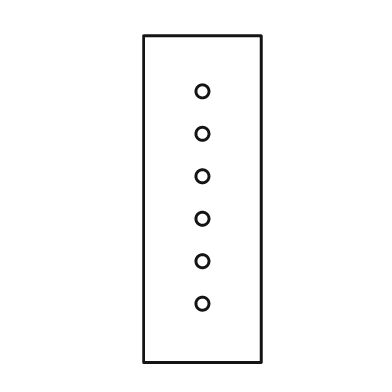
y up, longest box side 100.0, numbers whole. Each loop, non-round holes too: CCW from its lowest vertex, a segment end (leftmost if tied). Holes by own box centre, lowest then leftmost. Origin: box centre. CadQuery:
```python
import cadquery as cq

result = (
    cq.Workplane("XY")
    .moveTo(-18.0, -50.0)
    .lineTo(18.0, -50.0)
    .lineTo(18.0, 50.0)
    .lineTo(-18.0, 50.0)
    .close()
    .moveTo(0.0, -32.0)
    .circle(2.0)
    .moveTo(0.0, -19.0)
    .circle(2.0)
    .moveTo(0.0, -6.0)
    .circle(2.0)
    .moveTo(0.0, 7.0)
    .circle(2.0)
    .moveTo(0.0, 20.0)
    .circle(2.0)
    .moveTo(0.0, 33.0)
    .circle(2.0)
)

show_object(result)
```